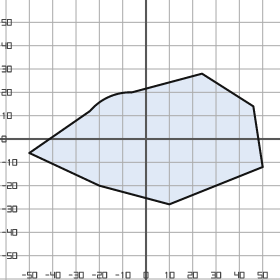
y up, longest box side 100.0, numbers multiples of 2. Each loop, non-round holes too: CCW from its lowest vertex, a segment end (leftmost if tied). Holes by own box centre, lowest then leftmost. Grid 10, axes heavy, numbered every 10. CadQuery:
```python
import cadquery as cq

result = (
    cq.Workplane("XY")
    .moveTo(10.0, -28.0)
    .lineTo(50.0, -12.0)
    .lineTo(46.0, 14.0)
    .lineTo(24.0, 28.0)
    .lineTo(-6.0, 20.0)
    .threePointArc((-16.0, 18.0), (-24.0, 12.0))
    .lineTo(-50.0, -6.0)
    .lineTo(-20.0, -20.0)
    .close()
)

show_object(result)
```